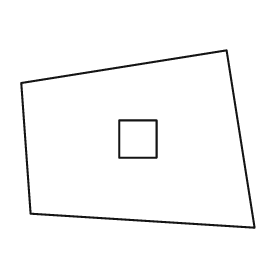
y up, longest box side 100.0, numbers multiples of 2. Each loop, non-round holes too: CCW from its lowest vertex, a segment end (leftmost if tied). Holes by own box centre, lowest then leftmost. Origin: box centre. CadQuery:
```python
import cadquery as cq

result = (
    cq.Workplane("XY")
    .moveTo(50.0, -38.0)
    .lineTo(38.0, 38.0)
    .lineTo(-50.0, 24.0)
    .lineTo(-46.0, -32.0)
    .close()
    .moveTo(-8.0, -8.0)
    .lineTo(8.0, -8.0)
    .lineTo(8.0, 8.0)
    .lineTo(-8.0, 8.0)
    .close()
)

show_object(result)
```